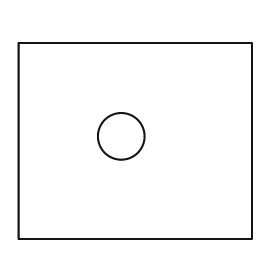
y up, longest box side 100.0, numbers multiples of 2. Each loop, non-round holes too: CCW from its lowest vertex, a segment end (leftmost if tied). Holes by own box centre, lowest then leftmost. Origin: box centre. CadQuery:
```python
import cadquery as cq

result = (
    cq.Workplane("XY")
    .moveTo(-50.0, -42.0)
    .lineTo(50.0, -42.0)
    .lineTo(50.0, 42.0)
    .lineTo(-50.0, 42.0)
    .close()
    .moveTo(-6.0, 2.0)
    .circle(10.0)
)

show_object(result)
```